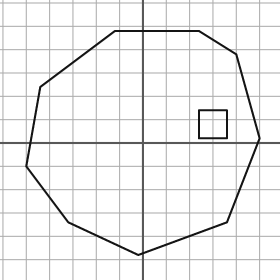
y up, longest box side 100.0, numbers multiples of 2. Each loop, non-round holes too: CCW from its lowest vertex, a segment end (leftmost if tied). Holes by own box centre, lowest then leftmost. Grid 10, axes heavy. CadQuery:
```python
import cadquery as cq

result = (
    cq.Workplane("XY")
    .moveTo(-2.0, -48.0)
    .lineTo(36.0, -34.0)
    .lineTo(50.0, 2.0)
    .lineTo(40.0, 38.0)
    .lineTo(24.0, 48.0)
    .lineTo(-12.0, 48.0)
    .lineTo(-44.0, 24.0)
    .lineTo(-50.0, -10.0)
    .lineTo(-32.0, -34.0)
    .close()
    .moveTo(24.0, 2.0)
    .lineTo(36.0, 2.0)
    .lineTo(36.0, 14.0)
    .lineTo(24.0, 14.0)
    .close()
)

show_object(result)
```